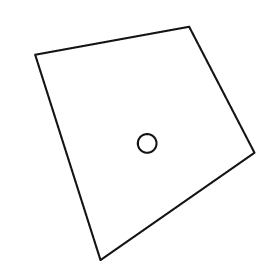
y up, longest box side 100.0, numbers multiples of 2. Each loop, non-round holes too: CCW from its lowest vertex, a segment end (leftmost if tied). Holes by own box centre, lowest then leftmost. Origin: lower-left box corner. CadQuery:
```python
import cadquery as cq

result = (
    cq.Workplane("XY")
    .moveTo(28.0, 0.0)
    .lineTo(94.0, 46.0)
    .lineTo(66.0, 100.0)
    .lineTo(0.0, 88.0)
    .close()
    .moveTo(48.0, 50.0)
    .circle(4.0)
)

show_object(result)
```